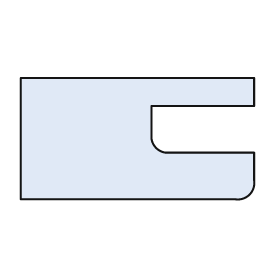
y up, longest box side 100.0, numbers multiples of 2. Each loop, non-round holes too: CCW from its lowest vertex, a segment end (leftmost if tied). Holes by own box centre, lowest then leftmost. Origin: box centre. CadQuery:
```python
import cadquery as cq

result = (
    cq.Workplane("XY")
    .moveTo(-50.0, -26.0)
    .lineTo(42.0, -26.0)
    .threePointArc((48.0, -24.0), (50.0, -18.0))
    .lineTo(50.0, -6.0)
    .lineTo(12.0, -6.0)
    .threePointArc((8.0, -4.0), (6.0, 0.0))
    .lineTo(6.0, 14.0)
    .lineTo(50.0, 14.0)
    .lineTo(50.0, 26.0)
    .lineTo(-50.0, 26.0)
    .close()
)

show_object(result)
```